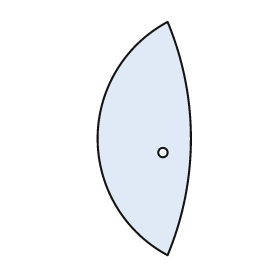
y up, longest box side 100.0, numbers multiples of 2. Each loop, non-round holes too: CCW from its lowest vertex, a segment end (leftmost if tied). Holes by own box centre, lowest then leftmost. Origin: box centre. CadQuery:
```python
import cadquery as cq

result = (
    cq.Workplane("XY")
    .moveTo(10.0, -50.0)
    .threePointArc((20.0, 0.0), (10.0, 50.0))
    .threePointArc((-20.0, 0.0), (10.0, -50.0))
    .close()
    .moveTo(8.0, -6.0)
    .circle(2.0)
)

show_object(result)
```